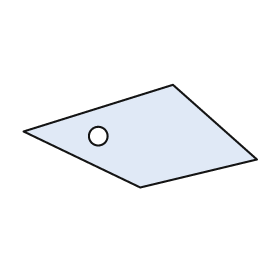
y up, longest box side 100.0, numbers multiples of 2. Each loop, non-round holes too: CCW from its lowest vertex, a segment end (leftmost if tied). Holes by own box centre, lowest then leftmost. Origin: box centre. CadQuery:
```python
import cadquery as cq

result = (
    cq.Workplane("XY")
    .moveTo(0.0, -22.0)
    .lineTo(50.0, -10.0)
    .lineTo(14.0, 22.0)
    .lineTo(-50.0, 2.0)
    .close()
    .moveTo(-18.0, 0.0)
    .circle(4.0)
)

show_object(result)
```